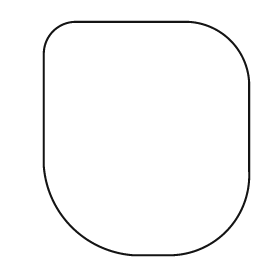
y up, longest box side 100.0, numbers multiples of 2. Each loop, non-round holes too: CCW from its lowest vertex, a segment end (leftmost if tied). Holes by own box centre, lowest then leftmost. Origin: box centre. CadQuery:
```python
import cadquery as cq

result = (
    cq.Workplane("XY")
    .moveTo(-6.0, -50.0)
    .lineTo(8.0, -50.0)
    .threePointArc((34.0, -40.0), (44.0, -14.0))
    .lineTo(44.0, 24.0)
    .threePointArc((36.0, 42.0), (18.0, 50.0))
    .lineTo(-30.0, 50.0)
    .threePointArc((-40.0, 46.0), (-44.0, 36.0))
    .lineTo(-44.0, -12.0)
    .threePointArc((-32.0, -38.0), (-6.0, -50.0))
    .close()
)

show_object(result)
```